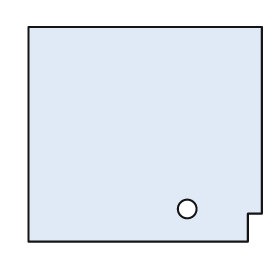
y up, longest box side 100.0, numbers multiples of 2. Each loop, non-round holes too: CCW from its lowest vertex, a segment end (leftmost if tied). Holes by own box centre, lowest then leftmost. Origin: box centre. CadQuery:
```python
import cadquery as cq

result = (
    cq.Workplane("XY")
    .moveTo(-50.0, -46.0)
    .lineTo(44.0, -46.0)
    .lineTo(44.0, -34.0)
    .lineTo(50.0, -34.0)
    .lineTo(50.0, 46.0)
    .lineTo(-50.0, 46.0)
    .close()
    .moveTo(18.0, -32.0)
    .circle(4.0)
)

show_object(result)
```